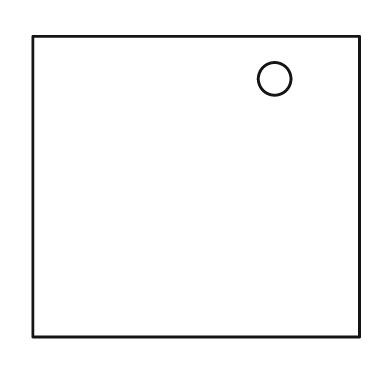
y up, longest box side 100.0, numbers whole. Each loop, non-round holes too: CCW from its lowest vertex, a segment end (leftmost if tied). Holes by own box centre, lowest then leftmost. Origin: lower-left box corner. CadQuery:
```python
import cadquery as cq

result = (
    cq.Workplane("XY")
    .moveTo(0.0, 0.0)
    .lineTo(100.0, 0.0)
    .lineTo(100.0, 92.0)
    .lineTo(0.0, 92.0)
    .close()
    .moveTo(74.0, 79.0)
    .circle(5.0)
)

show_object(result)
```